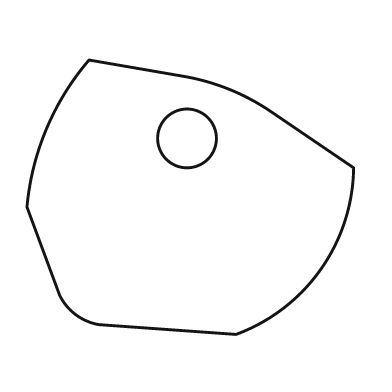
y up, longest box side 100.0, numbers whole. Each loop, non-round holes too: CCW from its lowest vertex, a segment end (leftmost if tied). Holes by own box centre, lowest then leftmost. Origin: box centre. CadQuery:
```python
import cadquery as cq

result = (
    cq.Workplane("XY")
    .moveTo(14.0, -42.0)
    .threePointArc((40.0, -22.0), (50.0, 9.0))
    .lineTo(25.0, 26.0)
    .threePointArc((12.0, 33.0), (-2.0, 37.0))
    .lineTo(-31.0, 42.0)
    .threePointArc((-44.0, 21.0), (-50.0, -3.0))
    .lineTo(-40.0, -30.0)
    .threePointArc((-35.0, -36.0), (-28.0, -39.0))
    .close()
    .moveTo(-1.0, 18.0)
    .circle(9.0)
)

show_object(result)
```